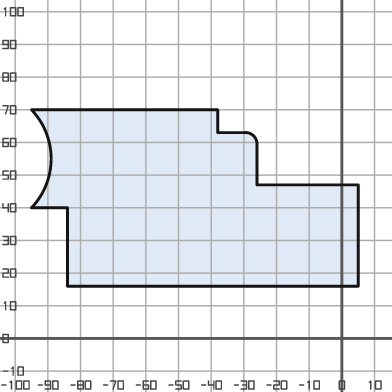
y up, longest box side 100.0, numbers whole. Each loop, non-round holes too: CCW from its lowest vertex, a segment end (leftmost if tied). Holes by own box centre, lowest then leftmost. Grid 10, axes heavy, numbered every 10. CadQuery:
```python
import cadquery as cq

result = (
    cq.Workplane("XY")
    .moveTo(-84.0, 16.0)
    .lineTo(5.0, 16.0)
    .lineTo(5.0, 47.0)
    .lineTo(-26.0, 47.0)
    .lineTo(-26.0, 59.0)
    .threePointArc((-27.0, 62.0), (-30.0, 63.0))
    .lineTo(-38.0, 63.0)
    .lineTo(-38.0, 70.0)
    .lineTo(-95.0, 70.0)
    .threePointArc((-89.0, 55.0), (-95.0, 40.0))
    .lineTo(-84.0, 40.0)
    .close()
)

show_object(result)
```